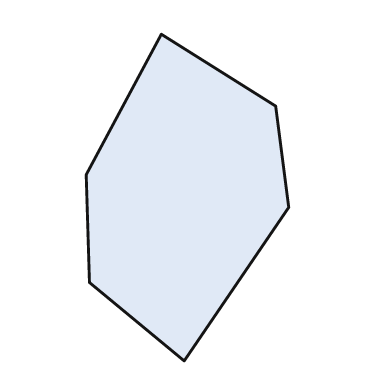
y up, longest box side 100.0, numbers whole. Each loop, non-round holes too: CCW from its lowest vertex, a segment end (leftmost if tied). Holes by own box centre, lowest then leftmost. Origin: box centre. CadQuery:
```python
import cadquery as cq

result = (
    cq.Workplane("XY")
    .moveTo(-1.0, -50.0)
    .lineTo(31.0, -3.0)
    .lineTo(27.0, 28.0)
    .lineTo(-8.0, 50.0)
    .lineTo(-31.0, 7.0)
    .lineTo(-30.0, -26.0)
    .close()
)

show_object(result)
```